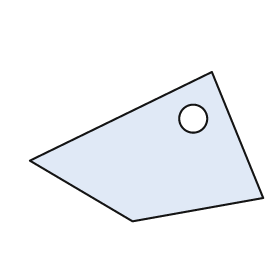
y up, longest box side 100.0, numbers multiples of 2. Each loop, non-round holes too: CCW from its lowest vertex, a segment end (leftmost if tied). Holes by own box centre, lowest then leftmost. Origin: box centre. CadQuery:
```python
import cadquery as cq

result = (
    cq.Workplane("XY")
    .moveTo(-6.0, -32.0)
    .lineTo(50.0, -22.0)
    .lineTo(28.0, 32.0)
    .lineTo(-50.0, -6.0)
    .close()
    .moveTo(20.0, 12.0)
    .circle(6.0)
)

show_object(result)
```